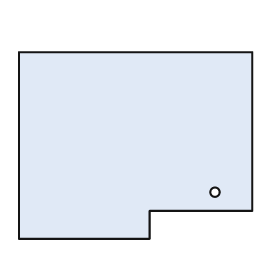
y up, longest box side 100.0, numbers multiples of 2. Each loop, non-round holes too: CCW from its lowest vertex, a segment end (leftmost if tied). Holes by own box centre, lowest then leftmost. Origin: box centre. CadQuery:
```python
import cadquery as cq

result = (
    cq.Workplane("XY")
    .moveTo(-50.0, -40.0)
    .lineTo(6.0, -40.0)
    .lineTo(6.0, -28.0)
    .lineTo(50.0, -28.0)
    .lineTo(50.0, 40.0)
    .lineTo(-50.0, 40.0)
    .close()
    .moveTo(34.0, -20.0)
    .circle(2.0)
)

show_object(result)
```